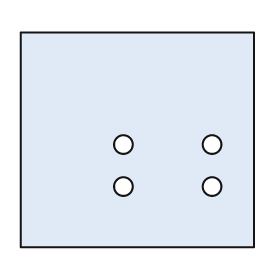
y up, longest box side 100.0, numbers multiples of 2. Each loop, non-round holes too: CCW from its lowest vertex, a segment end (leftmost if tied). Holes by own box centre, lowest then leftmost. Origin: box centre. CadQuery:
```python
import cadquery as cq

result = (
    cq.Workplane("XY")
    .moveTo(-50.0, -46.0)
    .lineTo(50.0, -46.0)
    .lineTo(50.0, 46.0)
    .lineTo(-50.0, 46.0)
    .close()
    .moveTo(-6.0, -20.0)
    .circle(4.0)
    .moveTo(32.0, -20.0)
    .circle(4.0)
    .moveTo(-6.0, -2.0)
    .circle(4.0)
    .moveTo(32.0, -2.0)
    .circle(4.0)
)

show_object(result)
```